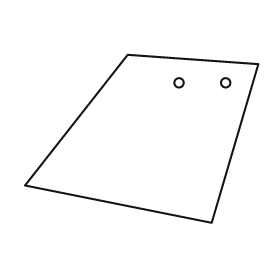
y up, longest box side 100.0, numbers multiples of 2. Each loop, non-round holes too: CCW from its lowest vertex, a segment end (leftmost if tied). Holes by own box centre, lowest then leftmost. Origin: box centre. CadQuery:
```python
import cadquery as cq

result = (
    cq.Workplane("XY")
    .moveTo(30.0, -36.0)
    .lineTo(50.0, 32.0)
    .lineTo(-6.0, 36.0)
    .lineTo(-50.0, -20.0)
    .close()
    .moveTo(16.0, 24.0)
    .circle(2.0)
    .moveTo(36.0, 24.0)
    .circle(2.0)
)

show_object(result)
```